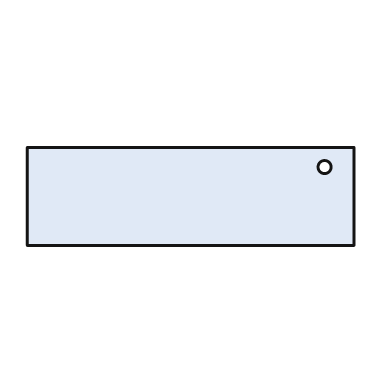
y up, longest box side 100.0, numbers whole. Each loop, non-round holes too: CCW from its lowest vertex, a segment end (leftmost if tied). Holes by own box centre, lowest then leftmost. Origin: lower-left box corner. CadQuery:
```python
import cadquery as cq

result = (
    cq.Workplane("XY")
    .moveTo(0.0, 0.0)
    .lineTo(100.0, 0.0)
    .lineTo(100.0, 30.0)
    .lineTo(0.0, 30.0)
    .close()
    .moveTo(91.0, 24.0)
    .circle(2.0)
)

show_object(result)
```